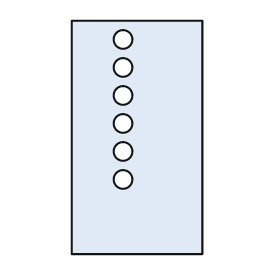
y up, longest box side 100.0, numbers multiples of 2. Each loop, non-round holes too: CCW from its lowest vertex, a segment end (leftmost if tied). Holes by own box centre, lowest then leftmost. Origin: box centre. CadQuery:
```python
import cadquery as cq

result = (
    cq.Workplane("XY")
    .moveTo(-28.0, -50.0)
    .lineTo(28.0, -50.0)
    .lineTo(28.0, 50.0)
    .lineTo(-28.0, 50.0)
    .close()
    .moveTo(-6.0, -18.0)
    .circle(4.0)
    .moveTo(-6.0, -6.0)
    .circle(4.0)
    .moveTo(-6.0, 6.0)
    .circle(4.0)
    .moveTo(-6.0, 18.0)
    .circle(4.0)
    .moveTo(-6.0, 30.0)
    .circle(4.0)
    .moveTo(-6.0, 42.0)
    .circle(4.0)
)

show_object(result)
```